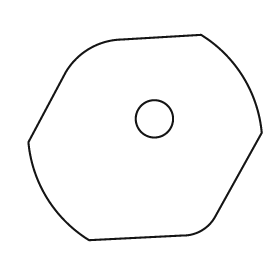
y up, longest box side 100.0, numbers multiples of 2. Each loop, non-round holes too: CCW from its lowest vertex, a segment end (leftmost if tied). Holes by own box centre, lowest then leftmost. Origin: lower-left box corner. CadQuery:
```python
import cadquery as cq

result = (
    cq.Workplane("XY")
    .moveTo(26.0, 0.0)
    .lineTo(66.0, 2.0)
    .threePointArc((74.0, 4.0), (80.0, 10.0))
    .lineTo(100.0, 46.0)
    .threePointArc((92.0, 70.0), (74.0, 88.0))
    .lineTo(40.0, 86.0)
    .threePointArc((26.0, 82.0), (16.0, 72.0))
    .lineTo(0.0, 42.0)
    .threePointArc((8.0, 18.0), (26.0, 0.0))
    .close()
    .moveTo(54.0, 52.0)
    .circle(8.0)
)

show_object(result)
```